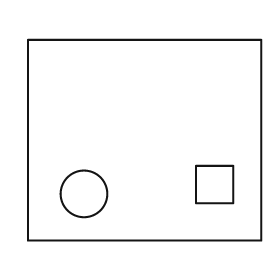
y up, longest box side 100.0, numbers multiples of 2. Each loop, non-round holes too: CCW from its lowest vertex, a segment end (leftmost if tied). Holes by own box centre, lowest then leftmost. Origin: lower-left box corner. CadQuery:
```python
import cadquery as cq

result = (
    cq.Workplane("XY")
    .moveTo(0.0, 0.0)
    .lineTo(100.0, 0.0)
    .lineTo(100.0, 86.0)
    .lineTo(0.0, 86.0)
    .close()
    .moveTo(24.0, 20.0)
    .circle(10.0)
    .moveTo(72.0, 16.0)
    .lineTo(88.0, 16.0)
    .lineTo(88.0, 32.0)
    .lineTo(72.0, 32.0)
    .close()
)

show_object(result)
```